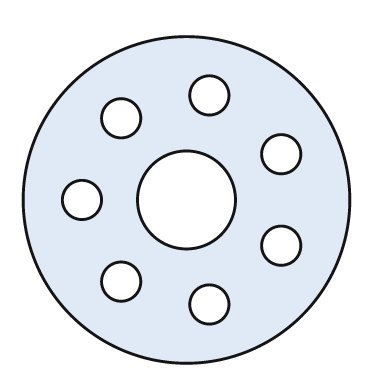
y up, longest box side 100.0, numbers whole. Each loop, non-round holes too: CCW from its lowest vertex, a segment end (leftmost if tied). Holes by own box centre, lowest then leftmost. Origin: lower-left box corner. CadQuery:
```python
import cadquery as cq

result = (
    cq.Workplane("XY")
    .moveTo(50.0, 50.0)
    .circle(50.0)
    .moveTo(57.0, 18.0)
    .circle(6.0)
    .moveTo(30.0, 25.0)
    .circle(6.0)
    .moveTo(79.0, 36.0)
    .circle(6.0)
    .moveTo(18.0, 50.0)
    .circle(6.0)
    .moveTo(50.0, 50.0)
    .circle(15.0)
    .moveTo(79.0, 64.0)
    .circle(6.0)
    .moveTo(30.0, 75.0)
    .circle(6.0)
    .moveTo(57.0, 82.0)
    .circle(6.0)
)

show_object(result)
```